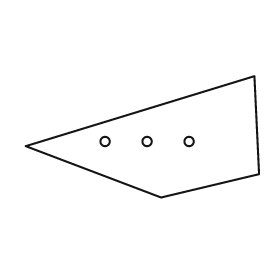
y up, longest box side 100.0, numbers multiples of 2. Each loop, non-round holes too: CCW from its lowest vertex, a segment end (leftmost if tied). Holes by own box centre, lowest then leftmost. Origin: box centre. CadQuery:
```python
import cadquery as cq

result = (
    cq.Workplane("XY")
    .moveTo(8.0, -26.0)
    .lineTo(50.0, -16.0)
    .lineTo(48.0, 26.0)
    .lineTo(-50.0, -4.0)
    .close()
    .moveTo(-16.0, -2.0)
    .circle(2.0)
    .moveTo(2.0, -2.0)
    .circle(2.0)
    .moveTo(20.0, -2.0)
    .circle(2.0)
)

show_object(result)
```